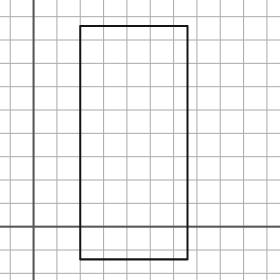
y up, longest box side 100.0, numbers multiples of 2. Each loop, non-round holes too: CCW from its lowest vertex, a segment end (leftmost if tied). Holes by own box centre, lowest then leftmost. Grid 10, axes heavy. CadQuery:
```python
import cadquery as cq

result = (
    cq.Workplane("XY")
    .moveTo(20.0, -14.0)
    .lineTo(66.0, -14.0)
    .lineTo(66.0, 86.0)
    .lineTo(20.0, 86.0)
    .close()
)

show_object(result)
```